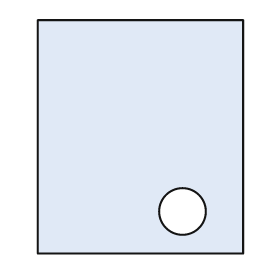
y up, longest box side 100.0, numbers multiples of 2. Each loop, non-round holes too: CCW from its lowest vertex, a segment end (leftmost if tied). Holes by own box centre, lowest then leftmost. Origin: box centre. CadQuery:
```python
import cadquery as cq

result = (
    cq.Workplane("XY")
    .moveTo(-44.0, -50.0)
    .lineTo(44.0, -50.0)
    .lineTo(44.0, 50.0)
    .lineTo(-44.0, 50.0)
    .close()
    .moveTo(18.0, -32.0)
    .circle(10.0)
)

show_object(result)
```